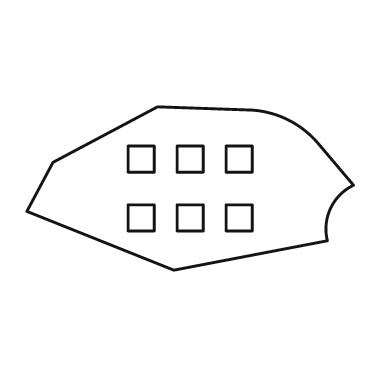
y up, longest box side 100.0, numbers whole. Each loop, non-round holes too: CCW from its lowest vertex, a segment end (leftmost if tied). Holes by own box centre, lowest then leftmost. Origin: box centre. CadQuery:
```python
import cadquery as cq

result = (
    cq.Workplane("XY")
    .moveTo(-5.0, -25.0)
    .lineTo(42.0, -16.0)
    .threePointArc((43.0, -6.0), (50.0, 1.0))
    .lineTo(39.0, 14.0)
    .threePointArc((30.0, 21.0), (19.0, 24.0))
    .lineTo(-10.0, 25.0)
    .lineTo(-42.0, 8.0)
    .lineTo(-50.0, -7.0)
    .close()
    .moveTo(-19.0, -13.0)
    .lineTo(-11.0, -13.0)
    .lineTo(-11.0, -5.0)
    .lineTo(-19.0, -5.0)
    .close()
    .moveTo(-4.0, -13.0)
    .lineTo(4.0, -13.0)
    .lineTo(4.0, -5.0)
    .lineTo(-4.0, -5.0)
    .close()
    .moveTo(11.0, -13.0)
    .lineTo(19.0, -13.0)
    .lineTo(19.0, -5.0)
    .lineTo(11.0, -5.0)
    .close()
    .moveTo(-19.0, 5.0)
    .lineTo(-11.0, 5.0)
    .lineTo(-11.0, 13.0)
    .lineTo(-19.0, 13.0)
    .close()
    .moveTo(-4.0, 5.0)
    .lineTo(4.0, 5.0)
    .lineTo(4.0, 13.0)
    .lineTo(-4.0, 13.0)
    .close()
    .moveTo(11.0, 5.0)
    .lineTo(19.0, 5.0)
    .lineTo(19.0, 13.0)
    .lineTo(11.0, 13.0)
    .close()
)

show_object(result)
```